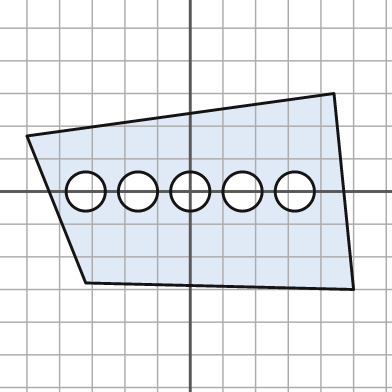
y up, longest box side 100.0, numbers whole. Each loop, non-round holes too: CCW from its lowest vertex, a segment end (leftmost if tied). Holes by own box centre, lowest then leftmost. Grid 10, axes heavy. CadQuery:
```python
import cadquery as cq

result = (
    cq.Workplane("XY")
    .moveTo(50.0, -30.0)
    .lineTo(44.0, 30.0)
    .lineTo(-50.0, 17.0)
    .lineTo(-32.0, -28.0)
    .close()
    .moveTo(-32.0, 0.0)
    .circle(6.0)
    .moveTo(-16.0, 0.0)
    .circle(6.0)
    .moveTo(0.0, 0.0)
    .circle(6.0)
    .moveTo(16.0, 0.0)
    .circle(6.0)
    .moveTo(32.0, 0.0)
    .circle(6.0)
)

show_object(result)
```